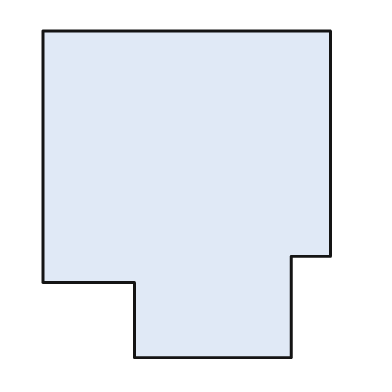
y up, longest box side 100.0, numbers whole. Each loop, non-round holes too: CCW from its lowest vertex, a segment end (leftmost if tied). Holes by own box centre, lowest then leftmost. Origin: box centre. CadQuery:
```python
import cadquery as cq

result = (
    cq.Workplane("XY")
    .moveTo(-16.0, -50.0)
    .lineTo(32.0, -50.0)
    .lineTo(32.0, -19.0)
    .lineTo(44.0, -19.0)
    .lineTo(44.0, 50.0)
    .lineTo(-44.0, 50.0)
    .lineTo(-44.0, -27.0)
    .lineTo(-16.0, -27.0)
    .close()
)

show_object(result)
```